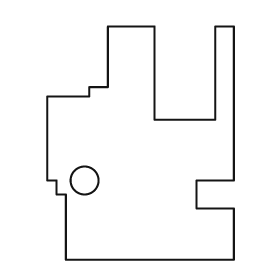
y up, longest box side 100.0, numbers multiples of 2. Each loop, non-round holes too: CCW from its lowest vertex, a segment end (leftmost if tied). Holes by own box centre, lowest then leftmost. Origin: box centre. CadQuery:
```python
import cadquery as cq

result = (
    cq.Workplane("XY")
    .moveTo(-32.0, -50.0)
    .lineTo(40.0, -50.0)
    .lineTo(40.0, -28.0)
    .lineTo(24.0, -28.0)
    .lineTo(24.0, -16.0)
    .lineTo(40.0, -16.0)
    .lineTo(40.0, 50.0)
    .lineTo(32.0, 50.0)
    .lineTo(32.0, 10.0)
    .lineTo(6.0, 10.0)
    .lineTo(6.0, 50.0)
    .lineTo(-14.0, 50.0)
    .lineTo(-14.0, 24.0)
    .lineTo(-22.0, 24.0)
    .lineTo(-22.0, 20.0)
    .lineTo(-40.0, 20.0)
    .lineTo(-40.0, -16.0)
    .lineTo(-36.0, -16.0)
    .lineTo(-36.0, -22.0)
    .lineTo(-32.0, -22.0)
    .close()
    .moveTo(-24.0, -16.0)
    .circle(6.0)
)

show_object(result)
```